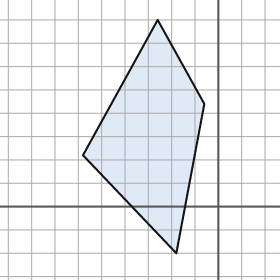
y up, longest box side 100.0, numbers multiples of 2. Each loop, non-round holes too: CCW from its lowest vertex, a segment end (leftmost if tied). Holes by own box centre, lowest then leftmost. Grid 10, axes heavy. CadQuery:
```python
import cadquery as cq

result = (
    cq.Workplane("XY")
    .moveTo(-18.0, -20.0)
    .lineTo(-6.0, 44.0)
    .lineTo(-26.0, 80.0)
    .lineTo(-58.0, 22.0)
    .close()
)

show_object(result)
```